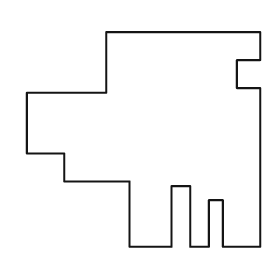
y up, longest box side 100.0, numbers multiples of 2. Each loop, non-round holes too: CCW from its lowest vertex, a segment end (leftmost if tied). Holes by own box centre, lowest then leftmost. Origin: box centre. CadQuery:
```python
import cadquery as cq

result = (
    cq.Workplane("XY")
    .moveTo(-6.0, -46.0)
    .lineTo(12.0, -46.0)
    .lineTo(12.0, -20.0)
    .lineTo(20.0, -20.0)
    .lineTo(20.0, -46.0)
    .lineTo(28.0, -46.0)
    .lineTo(28.0, -26.0)
    .lineTo(34.0, -26.0)
    .lineTo(34.0, -46.0)
    .lineTo(50.0, -46.0)
    .lineTo(50.0, 22.0)
    .lineTo(40.0, 22.0)
    .lineTo(40.0, 34.0)
    .lineTo(50.0, 34.0)
    .lineTo(50.0, 46.0)
    .lineTo(-16.0, 46.0)
    .lineTo(-16.0, 20.0)
    .lineTo(-50.0, 20.0)
    .lineTo(-50.0, -6.0)
    .lineTo(-34.0, -6.0)
    .lineTo(-34.0, -18.0)
    .lineTo(-6.0, -18.0)
    .close()
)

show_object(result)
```